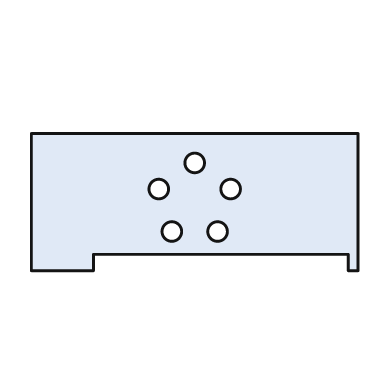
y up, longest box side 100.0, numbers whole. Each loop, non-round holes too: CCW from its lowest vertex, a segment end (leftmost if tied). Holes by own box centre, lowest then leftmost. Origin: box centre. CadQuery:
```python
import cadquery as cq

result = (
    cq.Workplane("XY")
    .moveTo(-50.0, -21.0)
    .lineTo(-31.0, -21.0)
    .lineTo(-31.0, -16.0)
    .lineTo(47.0, -16.0)
    .lineTo(47.0, -21.0)
    .lineTo(50.0, -21.0)
    .lineTo(50.0, 21.0)
    .lineTo(-50.0, 21.0)
    .close()
    .moveTo(-7.0, -9.0)
    .circle(3.0)
    .moveTo(7.0, -9.0)
    .circle(3.0)
    .moveTo(-11.0, 4.0)
    .circle(3.0)
    .moveTo(11.0, 4.0)
    .circle(3.0)
    .moveTo(0.0, 12.0)
    .circle(3.0)
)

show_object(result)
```